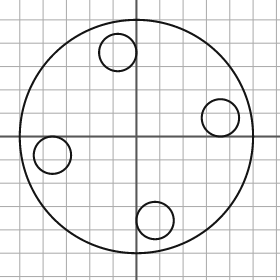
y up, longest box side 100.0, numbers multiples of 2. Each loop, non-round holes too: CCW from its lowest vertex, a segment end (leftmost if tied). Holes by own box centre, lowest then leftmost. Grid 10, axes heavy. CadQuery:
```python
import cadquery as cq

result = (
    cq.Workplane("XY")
    .moveTo(0.0, 0.0)
    .circle(50.0)
    .moveTo(8.0, -36.0)
    .circle(8.0)
    .moveTo(-36.0, -8.0)
    .circle(8.0)
    .moveTo(36.0, 8.0)
    .circle(8.0)
    .moveTo(-8.0, 36.0)
    .circle(8.0)
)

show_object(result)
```